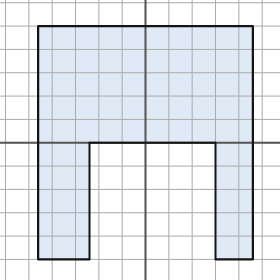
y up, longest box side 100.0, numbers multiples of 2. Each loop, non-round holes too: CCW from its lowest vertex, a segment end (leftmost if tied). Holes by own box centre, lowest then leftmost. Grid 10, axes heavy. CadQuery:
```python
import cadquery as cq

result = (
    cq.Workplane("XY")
    .moveTo(-46.0, -50.0)
    .lineTo(-24.0, -50.0)
    .lineTo(-24.0, 0.0)
    .lineTo(30.0, 0.0)
    .lineTo(30.0, -50.0)
    .lineTo(46.0, -50.0)
    .lineTo(46.0, 50.0)
    .lineTo(-46.0, 50.0)
    .close()
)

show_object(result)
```